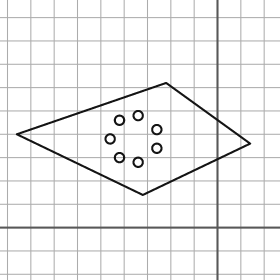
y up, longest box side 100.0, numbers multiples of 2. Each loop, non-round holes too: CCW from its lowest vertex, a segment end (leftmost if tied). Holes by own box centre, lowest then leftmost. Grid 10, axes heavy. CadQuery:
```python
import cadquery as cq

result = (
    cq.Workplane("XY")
    .moveTo(-32.0, 14.0)
    .lineTo(14.0, 36.0)
    .lineTo(-22.0, 62.0)
    .lineTo(-86.0, 40.0)
    .close()
    .moveTo(-34.0, 28.0)
    .circle(2.0)
    .moveTo(-42.0, 30.0)
    .circle(2.0)
    .moveTo(-26.0, 34.0)
    .circle(2.0)
    .moveTo(-46.0, 38.0)
    .circle(2.0)
    .moveTo(-26.0, 42.0)
    .circle(2.0)
    .moveTo(-42.0, 46.0)
    .circle(2.0)
    .moveTo(-34.0, 48.0)
    .circle(2.0)
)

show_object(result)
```